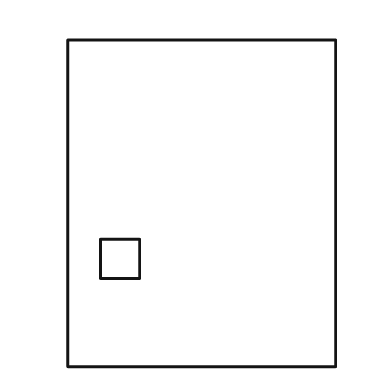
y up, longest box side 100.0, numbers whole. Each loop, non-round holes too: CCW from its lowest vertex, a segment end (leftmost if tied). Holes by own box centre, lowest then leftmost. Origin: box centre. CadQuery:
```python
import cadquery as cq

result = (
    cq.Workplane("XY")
    .moveTo(-41.0, -50.0)
    .lineTo(41.0, -50.0)
    .lineTo(41.0, 50.0)
    .lineTo(-41.0, 50.0)
    .close()
    .moveTo(-31.0, -23.0)
    .lineTo(-19.0, -23.0)
    .lineTo(-19.0, -11.0)
    .lineTo(-31.0, -11.0)
    .close()
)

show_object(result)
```